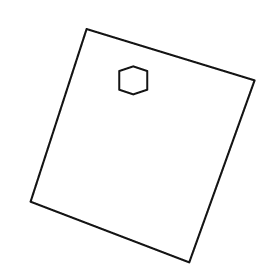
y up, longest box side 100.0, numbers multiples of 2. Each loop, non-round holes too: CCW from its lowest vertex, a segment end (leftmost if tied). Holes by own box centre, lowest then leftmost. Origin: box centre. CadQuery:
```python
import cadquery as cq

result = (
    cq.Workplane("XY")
    .moveTo(20.0, -50.0)
    .lineTo(48.0, 28.0)
    .lineTo(-24.0, 50.0)
    .lineTo(-48.0, -24.0)
    .close()
    .moveTo(-4.0, 22.0)
    .lineTo(2.0, 24.0)
    .lineTo(2.0, 32.0)
    .lineTo(-4.0, 34.0)
    .lineTo(-10.0, 32.0)
    .lineTo(-10.0, 24.0)
    .close()
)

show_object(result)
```